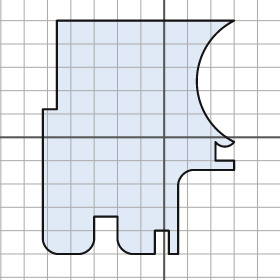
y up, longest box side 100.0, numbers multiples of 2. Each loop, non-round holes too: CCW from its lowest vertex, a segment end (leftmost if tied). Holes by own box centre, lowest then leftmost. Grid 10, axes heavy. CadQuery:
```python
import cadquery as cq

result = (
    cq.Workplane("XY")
    .moveTo(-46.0, -50.0)
    .lineTo(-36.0, -50.0)
    .threePointArc((-32.0, -48.0), (-30.0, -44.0))
    .lineTo(-30.0, -34.0)
    .lineTo(-20.0, -34.0)
    .lineTo(-20.0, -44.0)
    .threePointArc((-18.0, -48.0), (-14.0, -50.0))
    .lineTo(-4.0, -50.0)
    .lineTo(-4.0, -40.0)
    .lineTo(2.0, -40.0)
    .lineTo(2.0, -50.0)
    .lineTo(6.0, -50.0)
    .lineTo(6.0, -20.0)
    .threePointArc((8.0, -16.0), (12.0, -14.0))
    .lineTo(30.0, -14.0)
    .lineTo(30.0, -10.0)
    .lineTo(22.0, -10.0)
    .lineTo(22.0, -2.0)
    .threePointArc((26.0, -4.0), (30.0, -2.0))
    .threePointArc((14.0, 24.0), (30.0, 50.0))
    .lineTo(-46.0, 50.0)
    .lineTo(-46.0, 12.0)
    .lineTo(-52.0, 12.0)
    .lineTo(-52.0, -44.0)
    .threePointArc((-50.0, -48.0), (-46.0, -50.0))
    .close()
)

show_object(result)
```